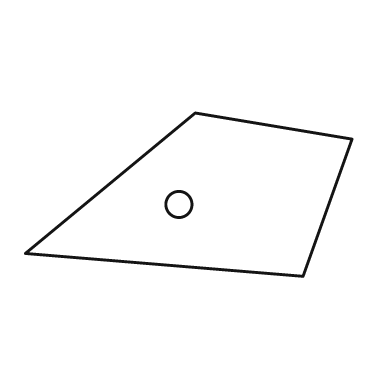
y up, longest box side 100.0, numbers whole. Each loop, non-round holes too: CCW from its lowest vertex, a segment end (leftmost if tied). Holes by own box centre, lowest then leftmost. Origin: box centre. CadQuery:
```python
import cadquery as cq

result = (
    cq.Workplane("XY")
    .moveTo(35.0, -25.0)
    .lineTo(50.0, 17.0)
    .lineTo(2.0, 25.0)
    .lineTo(-50.0, -18.0)
    .close()
    .moveTo(-3.0, -3.0)
    .circle(4.0)
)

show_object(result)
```